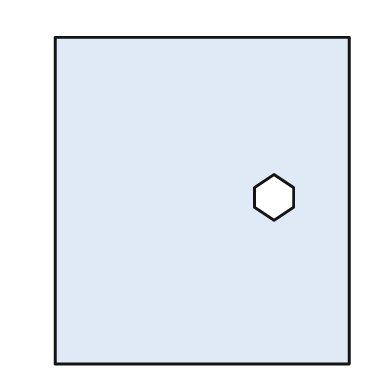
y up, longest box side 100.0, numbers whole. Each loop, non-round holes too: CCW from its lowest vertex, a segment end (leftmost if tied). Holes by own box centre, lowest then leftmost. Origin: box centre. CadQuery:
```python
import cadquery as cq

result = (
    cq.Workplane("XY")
    .moveTo(-45.0, -50.0)
    .lineTo(45.0, -50.0)
    .lineTo(45.0, 50.0)
    .lineTo(-45.0, 50.0)
    .close()
    .moveTo(22.0, -6.0)
    .lineTo(28.0, -2.0)
    .lineTo(28.0, 4.0)
    .lineTo(22.0, 8.0)
    .lineTo(16.0, 4.0)
    .lineTo(16.0, -2.0)
    .close()
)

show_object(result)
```